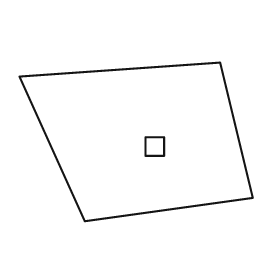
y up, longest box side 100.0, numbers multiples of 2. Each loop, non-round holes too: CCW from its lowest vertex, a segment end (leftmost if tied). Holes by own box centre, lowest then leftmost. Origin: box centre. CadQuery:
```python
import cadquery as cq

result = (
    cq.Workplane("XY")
    .moveTo(-22.0, -34.0)
    .lineTo(50.0, -24.0)
    .lineTo(36.0, 34.0)
    .lineTo(-50.0, 28.0)
    .close()
    .moveTo(4.0, -6.0)
    .lineTo(12.0, -6.0)
    .lineTo(12.0, 2.0)
    .lineTo(4.0, 2.0)
    .close()
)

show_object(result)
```